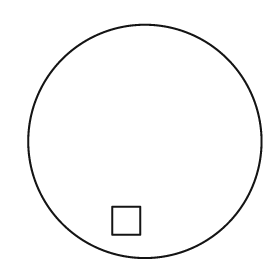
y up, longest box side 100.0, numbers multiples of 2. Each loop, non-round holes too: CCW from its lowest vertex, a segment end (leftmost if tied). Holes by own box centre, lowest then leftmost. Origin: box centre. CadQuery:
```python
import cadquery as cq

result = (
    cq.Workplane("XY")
    .moveTo(0.0, 0.0)
    .circle(50.0)
    .moveTo(-14.0, -40.0)
    .lineTo(-2.0, -40.0)
    .lineTo(-2.0, -28.0)
    .lineTo(-14.0, -28.0)
    .close()
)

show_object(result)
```